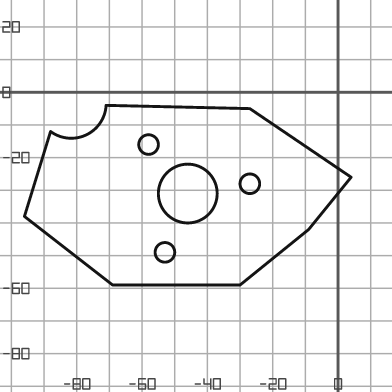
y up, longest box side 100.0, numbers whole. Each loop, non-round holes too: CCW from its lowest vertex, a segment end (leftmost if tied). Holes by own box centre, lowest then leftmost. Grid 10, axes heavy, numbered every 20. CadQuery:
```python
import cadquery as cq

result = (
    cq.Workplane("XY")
    .moveTo(-69.0, -59.0)
    .lineTo(-30.0, -59.0)
    .lineTo(-9.0, -42.0)
    .lineTo(4.0, -26.0)
    .lineTo(-27.0, -5.0)
    .lineTo(-71.0, -4.0)
    .threePointArc((-77.0, -13.0), (-88.0, -12.0))
    .lineTo(-96.0, -38.0)
    .close()
    .moveTo(-53.0, -49.0)
    .circle(3.0)
    .moveTo(-46.0, -31.0)
    .circle(9.0)
    .moveTo(-27.0, -28.0)
    .circle(3.0)
    .moveTo(-58.0, -16.0)
    .circle(3.0)
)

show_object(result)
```